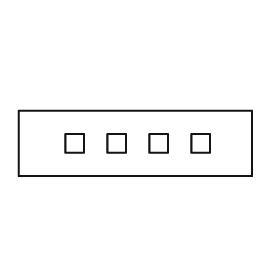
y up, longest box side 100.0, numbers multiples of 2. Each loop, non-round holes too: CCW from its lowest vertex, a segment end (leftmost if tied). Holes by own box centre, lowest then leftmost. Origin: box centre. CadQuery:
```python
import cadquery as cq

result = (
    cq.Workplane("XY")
    .moveTo(-50.0, -14.0)
    .lineTo(50.0, -14.0)
    .lineTo(50.0, 14.0)
    .lineTo(-50.0, 14.0)
    .close()
    .moveTo(-30.0, -4.0)
    .lineTo(-22.0, -4.0)
    .lineTo(-22.0, 4.0)
    .lineTo(-30.0, 4.0)
    .close()
    .moveTo(-12.0, -4.0)
    .lineTo(-4.0, -4.0)
    .lineTo(-4.0, 4.0)
    .lineTo(-12.0, 4.0)
    .close()
    .moveTo(6.0, -4.0)
    .lineTo(14.0, -4.0)
    .lineTo(14.0, 4.0)
    .lineTo(6.0, 4.0)
    .close()
    .moveTo(24.0, -4.0)
    .lineTo(32.0, -4.0)
    .lineTo(32.0, 4.0)
    .lineTo(24.0, 4.0)
    .close()
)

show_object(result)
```